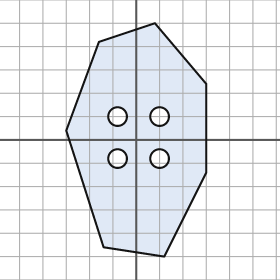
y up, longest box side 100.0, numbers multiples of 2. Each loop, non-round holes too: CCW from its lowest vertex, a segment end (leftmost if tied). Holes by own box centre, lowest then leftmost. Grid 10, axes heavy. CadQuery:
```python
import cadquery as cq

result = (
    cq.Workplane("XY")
    .moveTo(12.0, -50.0)
    .lineTo(30.0, -14.0)
    .lineTo(30.0, 24.0)
    .lineTo(8.0, 50.0)
    .lineTo(-16.0, 42.0)
    .lineTo(-30.0, 4.0)
    .lineTo(-14.0, -46.0)
    .close()
    .moveTo(-8.0, -8.0)
    .circle(4.0)
    .moveTo(10.0, -8.0)
    .circle(4.0)
    .moveTo(-8.0, 10.0)
    .circle(4.0)
    .moveTo(10.0, 10.0)
    .circle(4.0)
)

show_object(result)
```